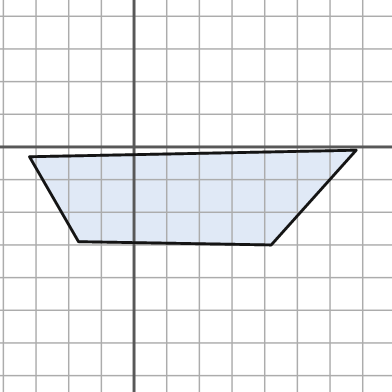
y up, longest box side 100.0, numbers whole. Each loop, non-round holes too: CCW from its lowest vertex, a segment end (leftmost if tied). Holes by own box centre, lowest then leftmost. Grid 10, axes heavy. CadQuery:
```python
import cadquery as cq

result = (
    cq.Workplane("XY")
    .moveTo(42.0, -30.0)
    .lineTo(68.0, -1.0)
    .lineTo(-32.0, -3.0)
    .lineTo(-17.0, -29.0)
    .close()
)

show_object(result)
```